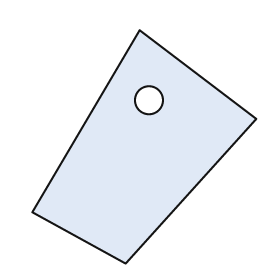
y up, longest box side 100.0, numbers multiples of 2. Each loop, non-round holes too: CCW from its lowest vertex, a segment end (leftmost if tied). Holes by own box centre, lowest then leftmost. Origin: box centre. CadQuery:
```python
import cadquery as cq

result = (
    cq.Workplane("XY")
    .moveTo(-8.0, -50.0)
    .lineTo(48.0, 12.0)
    .lineTo(-2.0, 50.0)
    .lineTo(-48.0, -28.0)
    .close()
    .moveTo(2.0, 20.0)
    .circle(6.0)
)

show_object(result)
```